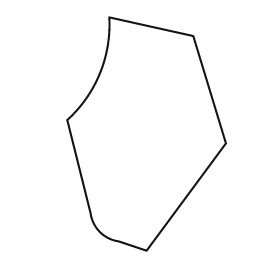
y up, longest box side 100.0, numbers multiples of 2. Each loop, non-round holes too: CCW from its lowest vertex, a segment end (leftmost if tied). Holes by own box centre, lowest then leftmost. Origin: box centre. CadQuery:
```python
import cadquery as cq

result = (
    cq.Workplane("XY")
    .moveTo(0.0, -50.0)
    .lineTo(34.0, -4.0)
    .lineTo(20.0, 42.0)
    .lineTo(-16.0, 50.0)
    .threePointArc((-20.0, 26.0), (-34.0, 6.0))
    .lineTo(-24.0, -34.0)
    .threePointArc((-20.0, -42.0), (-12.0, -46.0))
    .close()
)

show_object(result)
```